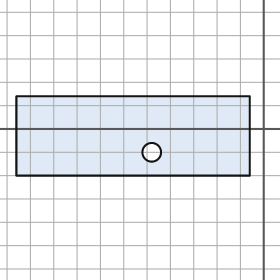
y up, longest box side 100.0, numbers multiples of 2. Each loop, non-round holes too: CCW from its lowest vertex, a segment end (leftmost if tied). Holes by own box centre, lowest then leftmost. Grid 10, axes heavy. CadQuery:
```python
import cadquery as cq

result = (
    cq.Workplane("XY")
    .moveTo(-106.0, -20.0)
    .lineTo(-6.0, -20.0)
    .lineTo(-6.0, 14.0)
    .lineTo(-106.0, 14.0)
    .close()
    .moveTo(-48.0, -10.0)
    .circle(4.0)
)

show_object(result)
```